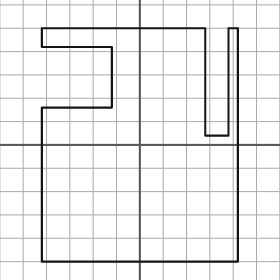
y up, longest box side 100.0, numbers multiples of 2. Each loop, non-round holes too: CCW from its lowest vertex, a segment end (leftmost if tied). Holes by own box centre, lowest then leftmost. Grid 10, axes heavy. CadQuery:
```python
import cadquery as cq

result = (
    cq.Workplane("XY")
    .moveTo(-42.0, -50.0)
    .lineTo(42.0, -50.0)
    .lineTo(42.0, 50.0)
    .lineTo(38.0, 50.0)
    .lineTo(38.0, 4.0)
    .lineTo(28.0, 4.0)
    .lineTo(28.0, 50.0)
    .lineTo(-42.0, 50.0)
    .lineTo(-42.0, 42.0)
    .lineTo(-12.0, 42.0)
    .lineTo(-12.0, 16.0)
    .lineTo(-42.0, 16.0)
    .close()
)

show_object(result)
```